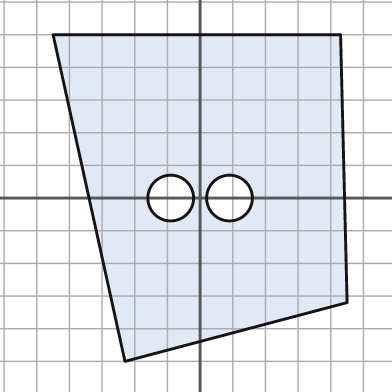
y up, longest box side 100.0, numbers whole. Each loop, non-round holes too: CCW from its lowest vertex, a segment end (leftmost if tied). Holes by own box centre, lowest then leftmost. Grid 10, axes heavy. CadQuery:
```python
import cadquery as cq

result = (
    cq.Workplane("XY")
    .moveTo(-23.0, -50.0)
    .lineTo(45.0, -32.0)
    .lineTo(43.0, 50.0)
    .lineTo(-45.0, 50.0)
    .close()
    .moveTo(-9.0, 0.0)
    .circle(7.0)
    .moveTo(9.0, 0.0)
    .circle(7.0)
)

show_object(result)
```